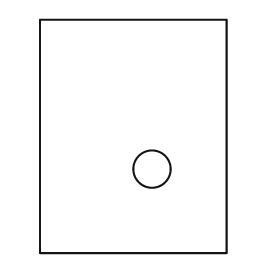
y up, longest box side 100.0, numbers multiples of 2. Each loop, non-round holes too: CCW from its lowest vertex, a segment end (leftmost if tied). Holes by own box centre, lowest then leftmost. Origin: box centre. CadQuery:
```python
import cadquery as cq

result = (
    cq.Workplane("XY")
    .moveTo(-40.0, -50.0)
    .lineTo(40.0, -50.0)
    .lineTo(40.0, 50.0)
    .lineTo(-40.0, 50.0)
    .close()
    .moveTo(8.0, -14.0)
    .circle(8.0)
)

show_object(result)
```